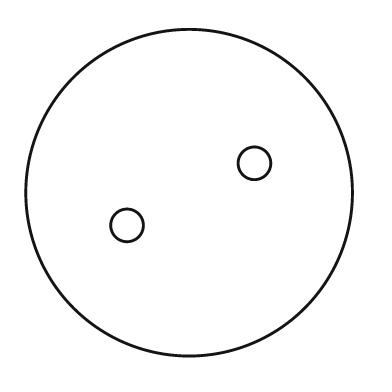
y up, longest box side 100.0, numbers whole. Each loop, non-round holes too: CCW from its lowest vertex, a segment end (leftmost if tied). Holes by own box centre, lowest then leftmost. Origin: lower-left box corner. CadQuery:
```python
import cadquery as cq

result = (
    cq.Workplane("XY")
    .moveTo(50.0, 50.0)
    .circle(50.0)
    .moveTo(31.0, 40.0)
    .circle(5.0)
    .moveTo(70.0, 59.0)
    .circle(5.0)
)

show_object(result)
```